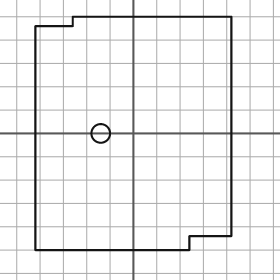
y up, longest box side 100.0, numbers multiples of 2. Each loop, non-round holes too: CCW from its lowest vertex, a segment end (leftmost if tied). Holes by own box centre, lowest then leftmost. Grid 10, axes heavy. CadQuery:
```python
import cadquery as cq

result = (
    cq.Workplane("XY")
    .moveTo(-42.0, -50.0)
    .lineTo(24.0, -50.0)
    .lineTo(24.0, -44.0)
    .lineTo(42.0, -44.0)
    .lineTo(42.0, 50.0)
    .lineTo(-26.0, 50.0)
    .lineTo(-26.0, 46.0)
    .lineTo(-42.0, 46.0)
    .close()
    .moveTo(-14.0, 0.0)
    .circle(4.0)
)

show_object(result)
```